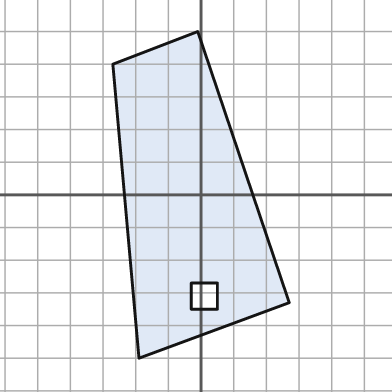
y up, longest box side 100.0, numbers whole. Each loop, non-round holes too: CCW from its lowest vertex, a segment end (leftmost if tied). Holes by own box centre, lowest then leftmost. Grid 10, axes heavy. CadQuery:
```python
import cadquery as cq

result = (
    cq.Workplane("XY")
    .moveTo(-19.0, -50.0)
    .lineTo(27.0, -33.0)
    .lineTo(-1.0, 50.0)
    .lineTo(-27.0, 40.0)
    .close()
    .moveTo(-3.0, -35.0)
    .lineTo(5.0, -35.0)
    .lineTo(5.0, -27.0)
    .lineTo(-3.0, -27.0)
    .close()
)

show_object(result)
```